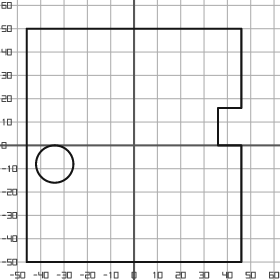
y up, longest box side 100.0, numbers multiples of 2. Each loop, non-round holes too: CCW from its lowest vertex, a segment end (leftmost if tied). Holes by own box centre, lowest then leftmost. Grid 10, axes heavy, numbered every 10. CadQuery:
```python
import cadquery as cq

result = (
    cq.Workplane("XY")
    .moveTo(-46.0, -50.0)
    .lineTo(46.0, -50.0)
    .lineTo(46.0, 0.0)
    .lineTo(36.0, 0.0)
    .lineTo(36.0, 16.0)
    .lineTo(46.0, 16.0)
    .lineTo(46.0, 50.0)
    .lineTo(-46.0, 50.0)
    .close()
    .moveTo(-34.0, -8.0)
    .circle(8.0)
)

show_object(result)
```